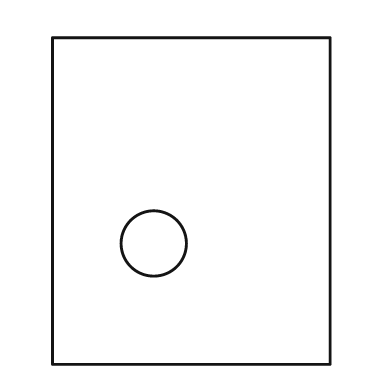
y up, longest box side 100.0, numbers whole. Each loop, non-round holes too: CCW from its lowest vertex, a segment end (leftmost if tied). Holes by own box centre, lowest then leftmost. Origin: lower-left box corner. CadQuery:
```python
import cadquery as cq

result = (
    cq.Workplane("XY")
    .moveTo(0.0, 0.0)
    .lineTo(85.0, 0.0)
    .lineTo(85.0, 100.0)
    .lineTo(0.0, 100.0)
    .close()
    .moveTo(31.0, 37.0)
    .circle(10.0)
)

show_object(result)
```